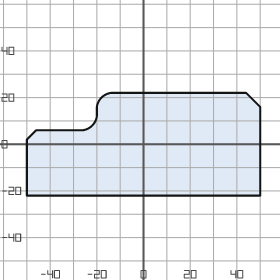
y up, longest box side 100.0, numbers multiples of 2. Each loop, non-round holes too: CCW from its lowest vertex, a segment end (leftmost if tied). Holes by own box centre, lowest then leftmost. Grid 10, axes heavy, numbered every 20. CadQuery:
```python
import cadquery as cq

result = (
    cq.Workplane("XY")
    .moveTo(-50.0, -22.0)
    .lineTo(50.0, -22.0)
    .lineTo(50.0, 16.0)
    .lineTo(44.0, 22.0)
    .lineTo(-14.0, 22.0)
    .threePointArc((-18.0, 20.0), (-20.0, 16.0))
    .lineTo(-20.0, 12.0)
    .threePointArc((-22.0, 8.0), (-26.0, 6.0))
    .lineTo(-46.0, 6.0)
    .lineTo(-50.0, 2.0)
    .close()
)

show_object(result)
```